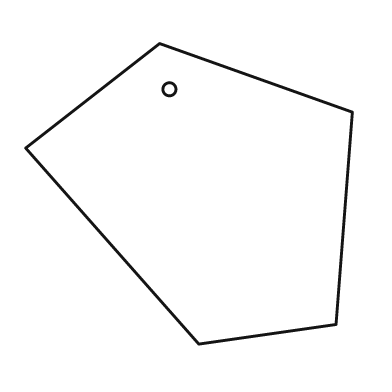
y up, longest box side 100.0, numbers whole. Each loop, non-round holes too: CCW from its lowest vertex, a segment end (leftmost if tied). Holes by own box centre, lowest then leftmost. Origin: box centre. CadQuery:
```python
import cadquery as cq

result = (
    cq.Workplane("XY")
    .moveTo(3.0, -46.0)
    .lineTo(45.0, -40.0)
    .lineTo(50.0, 25.0)
    .lineTo(-9.0, 46.0)
    .lineTo(-50.0, 14.0)
    .close()
    .moveTo(-6.0, 32.0)
    .circle(2.0)
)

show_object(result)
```